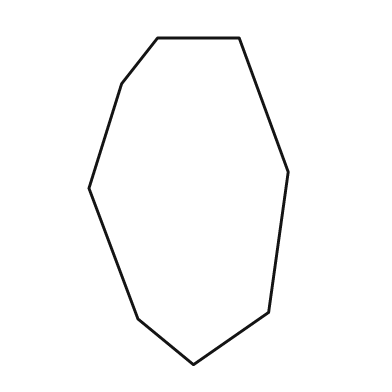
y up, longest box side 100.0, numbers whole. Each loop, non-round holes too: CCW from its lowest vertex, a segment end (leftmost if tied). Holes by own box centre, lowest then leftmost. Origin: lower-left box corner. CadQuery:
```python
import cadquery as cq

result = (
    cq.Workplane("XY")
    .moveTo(32.0, 0.0)
    .lineTo(55.0, 16.0)
    .lineTo(61.0, 59.0)
    .lineTo(46.0, 100.0)
    .lineTo(21.0, 100.0)
    .lineTo(10.0, 86.0)
    .lineTo(0.0, 54.0)
    .lineTo(15.0, 14.0)
    .close()
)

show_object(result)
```